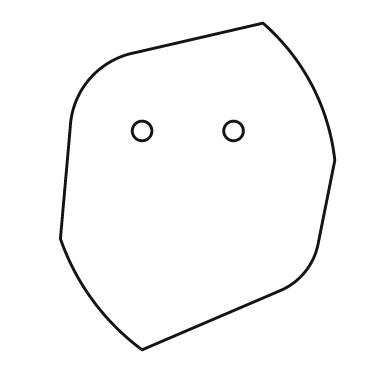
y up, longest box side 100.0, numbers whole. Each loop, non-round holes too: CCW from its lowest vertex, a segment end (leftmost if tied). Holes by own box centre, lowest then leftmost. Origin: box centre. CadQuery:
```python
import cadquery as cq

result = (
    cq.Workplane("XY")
    .moveTo(-17.0, -50.0)
    .lineTo(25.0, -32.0)
    .threePointArc((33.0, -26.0), (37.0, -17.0))
    .lineTo(42.0, 8.0)
    .threePointArc((35.0, 31.0), (20.0, 50.0))
    .lineTo(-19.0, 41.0)
    .threePointArc((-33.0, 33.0), (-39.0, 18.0))
    .lineTo(-42.0, -16.0)
    .threePointArc((-32.0, -35.0), (-17.0, -50.0))
    .close()
    .moveTo(-17.0, 17.0)
    .circle(3.0)
    .moveTo(11.0, 17.0)
    .circle(3.0)
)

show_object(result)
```